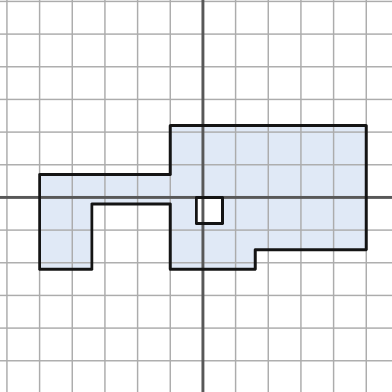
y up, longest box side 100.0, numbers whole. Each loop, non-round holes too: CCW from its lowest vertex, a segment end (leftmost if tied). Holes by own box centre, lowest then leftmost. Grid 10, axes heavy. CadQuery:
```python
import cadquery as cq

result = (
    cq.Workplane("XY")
    .moveTo(-50.0, -22.0)
    .lineTo(-34.0, -22.0)
    .lineTo(-34.0, -2.0)
    .lineTo(-10.0, -2.0)
    .lineTo(-10.0, -22.0)
    .lineTo(16.0, -22.0)
    .lineTo(16.0, -16.0)
    .lineTo(50.0, -16.0)
    .lineTo(50.0, 22.0)
    .lineTo(-10.0, 22.0)
    .lineTo(-10.0, 7.0)
    .lineTo(-50.0, 7.0)
    .close()
    .moveTo(-2.0, -8.0)
    .lineTo(6.0, -8.0)
    .lineTo(6.0, 0.0)
    .lineTo(-2.0, 0.0)
    .close()
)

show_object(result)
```